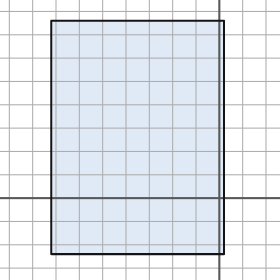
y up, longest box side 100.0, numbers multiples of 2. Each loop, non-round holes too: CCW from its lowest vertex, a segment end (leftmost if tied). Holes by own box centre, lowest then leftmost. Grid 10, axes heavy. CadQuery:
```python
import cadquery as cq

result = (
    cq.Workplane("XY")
    .moveTo(-72.0, -24.0)
    .lineTo(2.0, -24.0)
    .lineTo(2.0, 76.0)
    .lineTo(-72.0, 76.0)
    .close()
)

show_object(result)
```